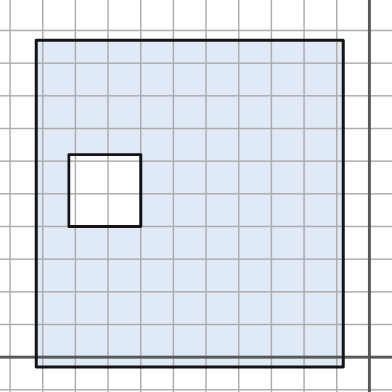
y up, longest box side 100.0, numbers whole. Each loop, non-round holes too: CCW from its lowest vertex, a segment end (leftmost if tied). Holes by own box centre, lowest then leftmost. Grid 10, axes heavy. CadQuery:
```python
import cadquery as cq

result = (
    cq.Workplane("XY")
    .moveTo(-102.0, -3.0)
    .lineTo(-8.0, -3.0)
    .lineTo(-8.0, 97.0)
    .lineTo(-102.0, 97.0)
    .close()
    .moveTo(-92.0, 40.0)
    .lineTo(-70.0, 40.0)
    .lineTo(-70.0, 62.0)
    .lineTo(-92.0, 62.0)
    .close()
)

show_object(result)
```